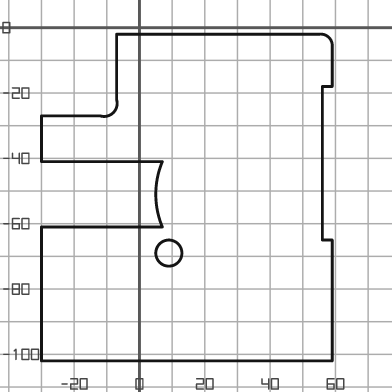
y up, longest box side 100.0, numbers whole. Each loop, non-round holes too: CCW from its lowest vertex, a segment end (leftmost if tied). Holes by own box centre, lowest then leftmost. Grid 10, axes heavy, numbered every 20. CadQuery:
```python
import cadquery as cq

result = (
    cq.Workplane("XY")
    .moveTo(-30.0, -102.0)
    .lineTo(59.0, -102.0)
    .lineTo(59.0, -65.0)
    .lineTo(56.0, -65.0)
    .lineTo(56.0, -18.0)
    .lineTo(59.0, -18.0)
    .lineTo(59.0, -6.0)
    .threePointArc((58.0, -3.0), (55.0, -2.0))
    .lineTo(-7.0, -2.0)
    .lineTo(-7.0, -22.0)
    .threePointArc((-8.0, -26.0), (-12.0, -27.0))
    .lineTo(-30.0, -27.0)
    .lineTo(-30.0, -41.0)
    .lineTo(7.0, -41.0)
    .threePointArc((5.0, -51.0), (7.0, -61.0))
    .lineTo(-30.0, -61.0)
    .close()
    .moveTo(9.0, -69.0)
    .circle(4.0)
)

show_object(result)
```